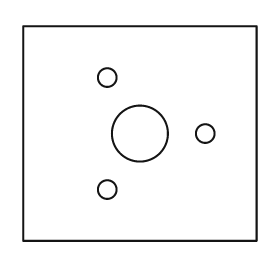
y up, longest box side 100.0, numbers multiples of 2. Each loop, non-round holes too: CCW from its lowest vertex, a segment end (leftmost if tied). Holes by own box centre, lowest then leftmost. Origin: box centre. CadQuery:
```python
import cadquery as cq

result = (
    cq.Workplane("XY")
    .moveTo(-50.0, -46.0)
    .lineTo(50.0, -46.0)
    .lineTo(50.0, 46.0)
    .lineTo(-50.0, 46.0)
    .close()
    .moveTo(-14.0, -24.0)
    .circle(4.0)
    .moveTo(0.0, 0.0)
    .circle(12.0)
    .moveTo(28.0, 0.0)
    .circle(4.0)
    .moveTo(-14.0, 24.0)
    .circle(4.0)
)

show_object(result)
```